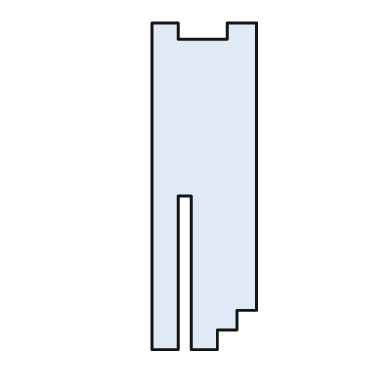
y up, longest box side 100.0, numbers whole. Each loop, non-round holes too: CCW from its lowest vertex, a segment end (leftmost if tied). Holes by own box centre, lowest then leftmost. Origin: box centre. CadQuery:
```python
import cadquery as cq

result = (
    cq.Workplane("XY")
    .moveTo(-16.0, -50.0)
    .lineTo(-8.0, -50.0)
    .lineTo(-8.0, -3.0)
    .lineTo(-4.0, -3.0)
    .lineTo(-4.0, -50.0)
    .lineTo(4.0, -50.0)
    .lineTo(4.0, -44.0)
    .lineTo(10.0, -44.0)
    .lineTo(10.0, -38.0)
    .lineTo(16.0, -38.0)
    .lineTo(16.0, 50.0)
    .lineTo(7.0, 50.0)
    .lineTo(7.0, 45.0)
    .lineTo(-8.0, 45.0)
    .lineTo(-8.0, 50.0)
    .lineTo(-16.0, 50.0)
    .close()
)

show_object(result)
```